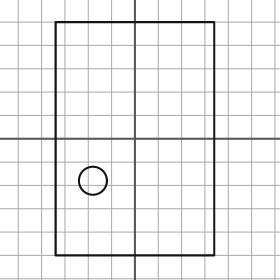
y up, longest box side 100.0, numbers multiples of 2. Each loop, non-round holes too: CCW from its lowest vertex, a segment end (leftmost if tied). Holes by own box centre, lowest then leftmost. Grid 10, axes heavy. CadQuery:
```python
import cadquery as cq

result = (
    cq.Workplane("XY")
    .moveTo(-34.0, -50.0)
    .lineTo(34.0, -50.0)
    .lineTo(34.0, 50.0)
    .lineTo(-34.0, 50.0)
    .close()
    .moveTo(-18.0, -18.0)
    .circle(6.0)
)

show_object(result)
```